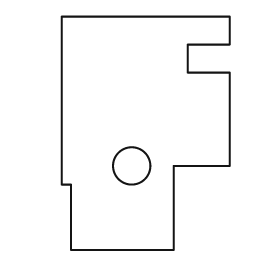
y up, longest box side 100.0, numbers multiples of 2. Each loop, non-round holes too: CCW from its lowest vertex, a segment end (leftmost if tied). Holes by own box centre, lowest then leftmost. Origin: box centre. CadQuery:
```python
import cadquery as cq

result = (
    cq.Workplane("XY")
    .moveTo(-32.0, -50.0)
    .lineTo(12.0, -50.0)
    .lineTo(12.0, -14.0)
    .lineTo(36.0, -14.0)
    .lineTo(36.0, 26.0)
    .lineTo(18.0, 26.0)
    .lineTo(18.0, 38.0)
    .lineTo(36.0, 38.0)
    .lineTo(36.0, 50.0)
    .lineTo(-36.0, 50.0)
    .lineTo(-36.0, -22.0)
    .lineTo(-32.0, -22.0)
    .close()
    .moveTo(-6.0, -14.0)
    .circle(8.0)
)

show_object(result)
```